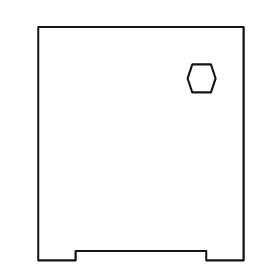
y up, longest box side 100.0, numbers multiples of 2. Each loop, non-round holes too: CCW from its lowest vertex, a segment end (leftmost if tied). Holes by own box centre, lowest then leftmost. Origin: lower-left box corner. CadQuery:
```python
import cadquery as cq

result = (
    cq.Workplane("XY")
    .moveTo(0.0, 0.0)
    .lineTo(16.0, 0.0)
    .lineTo(16.0, 4.0)
    .lineTo(72.0, 4.0)
    .lineTo(72.0, 0.0)
    .lineTo(88.0, 0.0)
    .lineTo(88.0, 100.0)
    .lineTo(0.0, 100.0)
    .close()
    .moveTo(66.0, 72.0)
    .lineTo(74.0, 72.0)
    .lineTo(76.0, 78.0)
    .lineTo(74.0, 84.0)
    .lineTo(66.0, 84.0)
    .lineTo(64.0, 78.0)
    .close()
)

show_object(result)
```